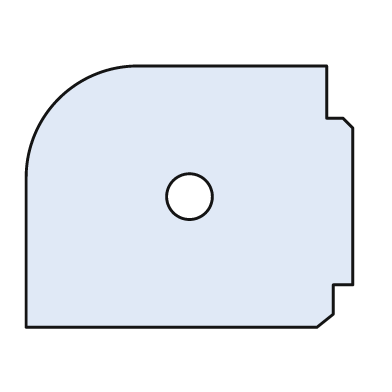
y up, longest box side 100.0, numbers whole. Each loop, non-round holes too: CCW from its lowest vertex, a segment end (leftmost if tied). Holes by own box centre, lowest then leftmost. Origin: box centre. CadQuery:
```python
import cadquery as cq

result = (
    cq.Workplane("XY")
    .moveTo(-50.0, -40.0)
    .lineTo(39.0, -40.0)
    .lineTo(44.0, -36.0)
    .lineTo(44.0, -27.0)
    .lineTo(50.0, -27.0)
    .lineTo(50.0, 21.0)
    .lineTo(47.0, 24.0)
    .lineTo(42.0, 24.0)
    .lineTo(42.0, 40.0)
    .lineTo(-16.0, 40.0)
    .threePointArc((-40.0, 30.0), (-50.0, 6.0))
    .close()
    .moveTo(0.0, 0.0)
    .circle(7.0)
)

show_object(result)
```